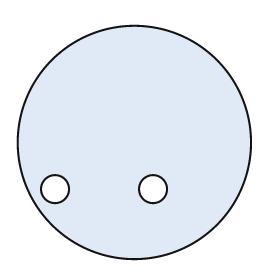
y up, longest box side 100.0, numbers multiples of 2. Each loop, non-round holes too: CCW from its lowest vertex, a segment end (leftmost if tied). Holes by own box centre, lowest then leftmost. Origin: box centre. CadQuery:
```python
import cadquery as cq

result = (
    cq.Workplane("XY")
    .moveTo(0.0, 0.0)
    .circle(50.0)
    .moveTo(-34.0, -20.0)
    .circle(6.0)
    .moveTo(8.0, -20.0)
    .circle(6.0)
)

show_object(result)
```